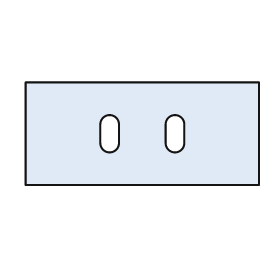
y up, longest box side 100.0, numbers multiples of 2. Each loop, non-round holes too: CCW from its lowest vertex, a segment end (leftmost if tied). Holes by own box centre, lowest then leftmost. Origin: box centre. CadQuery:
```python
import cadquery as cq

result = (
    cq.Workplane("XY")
    .moveTo(-50.0, -22.0)
    .lineTo(50.0, -22.0)
    .lineTo(50.0, 22.0)
    .lineTo(-50.0, 22.0)
    .close()
    .moveTo(-18.0, -4.0)
    .threePointArc((-14.0, -8.0), (-10.0, -4.0))
    .lineTo(-10.0, 4.0)
    .threePointArc((-14.0, 8.0), (-18.0, 4.0))
    .close()
    .moveTo(10.0, -4.0)
    .threePointArc((14.0, -8.0), (18.0, -4.0))
    .lineTo(18.0, 4.0)
    .threePointArc((14.0, 8.0), (10.0, 4.0))
    .close()
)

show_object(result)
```